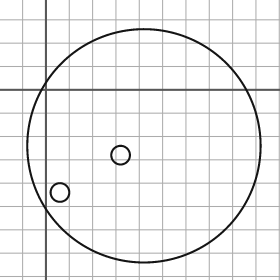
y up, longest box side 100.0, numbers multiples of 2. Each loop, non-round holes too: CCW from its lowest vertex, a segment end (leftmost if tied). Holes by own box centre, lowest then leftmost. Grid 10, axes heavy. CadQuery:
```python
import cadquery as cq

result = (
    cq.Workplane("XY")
    .moveTo(42.0, -24.0)
    .circle(50.0)
    .moveTo(6.0, -44.0)
    .circle(4.0)
    .moveTo(32.0, -28.0)
    .circle(4.0)
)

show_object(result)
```